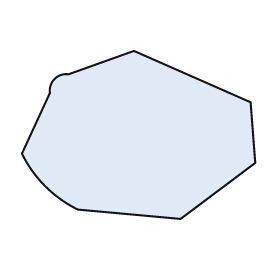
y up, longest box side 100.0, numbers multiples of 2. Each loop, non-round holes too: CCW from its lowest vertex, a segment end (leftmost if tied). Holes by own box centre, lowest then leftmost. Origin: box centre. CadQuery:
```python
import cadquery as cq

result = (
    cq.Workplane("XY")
    .moveTo(18.0, -36.0)
    .lineTo(50.0, -12.0)
    .lineTo(48.0, 14.0)
    .lineTo(-2.0, 36.0)
    .lineTo(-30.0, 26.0)
    .threePointArc((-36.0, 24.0), (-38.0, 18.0))
    .lineTo(-50.0, -8.0)
    .threePointArc((-40.0, -22.0), (-26.0, -32.0))
    .close()
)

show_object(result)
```